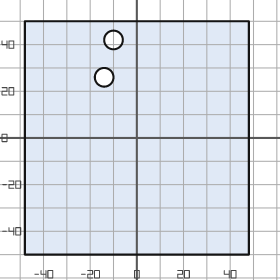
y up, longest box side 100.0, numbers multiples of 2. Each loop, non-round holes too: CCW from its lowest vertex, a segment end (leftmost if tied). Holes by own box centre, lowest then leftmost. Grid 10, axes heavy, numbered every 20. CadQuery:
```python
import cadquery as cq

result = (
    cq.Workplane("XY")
    .moveTo(-48.0, -50.0)
    .lineTo(48.0, -50.0)
    .lineTo(48.0, 50.0)
    .lineTo(-48.0, 50.0)
    .close()
    .moveTo(-14.0, 26.0)
    .circle(4.0)
    .moveTo(-10.0, 42.0)
    .circle(4.0)
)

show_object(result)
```